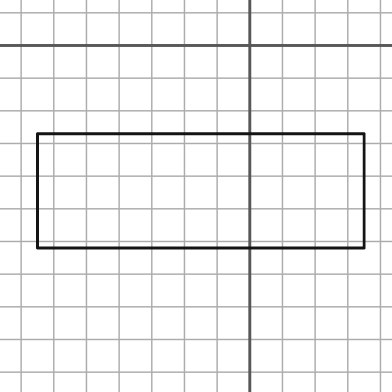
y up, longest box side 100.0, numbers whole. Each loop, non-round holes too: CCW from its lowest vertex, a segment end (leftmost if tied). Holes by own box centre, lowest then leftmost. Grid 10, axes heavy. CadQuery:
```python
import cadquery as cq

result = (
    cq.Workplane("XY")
    .moveTo(-65.0, -62.0)
    .lineTo(35.0, -62.0)
    .lineTo(35.0, -27.0)
    .lineTo(-65.0, -27.0)
    .close()
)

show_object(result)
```